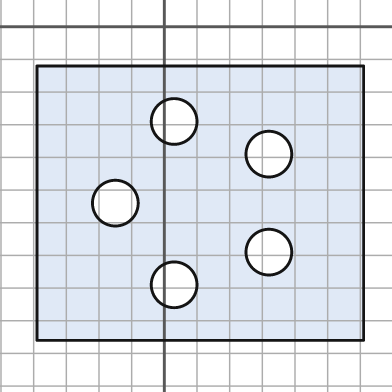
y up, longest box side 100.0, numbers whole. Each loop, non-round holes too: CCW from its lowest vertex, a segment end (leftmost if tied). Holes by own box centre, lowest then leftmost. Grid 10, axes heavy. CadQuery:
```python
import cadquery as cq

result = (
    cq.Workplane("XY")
    .moveTo(-39.0, -96.0)
    .lineTo(61.0, -96.0)
    .lineTo(61.0, -12.0)
    .lineTo(-39.0, -12.0)
    .close()
    .moveTo(3.0, -79.0)
    .circle(7.0)
    .moveTo(32.0, -69.0)
    .circle(7.0)
    .moveTo(-15.0, -54.0)
    .circle(7.0)
    .moveTo(32.0, -39.0)
    .circle(7.0)
    .moveTo(3.0, -29.0)
    .circle(7.0)
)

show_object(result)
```